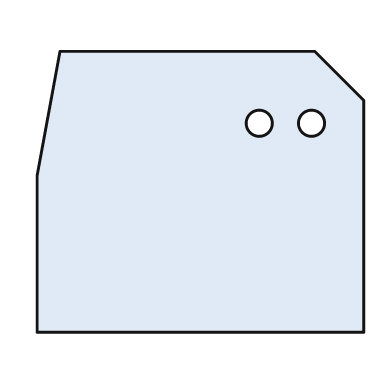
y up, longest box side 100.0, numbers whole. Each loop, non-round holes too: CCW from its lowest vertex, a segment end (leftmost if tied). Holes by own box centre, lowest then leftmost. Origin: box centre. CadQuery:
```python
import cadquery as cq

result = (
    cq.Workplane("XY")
    .moveTo(-50.0, -43.0)
    .lineTo(50.0, -43.0)
    .lineTo(50.0, 28.0)
    .lineTo(35.0, 43.0)
    .lineTo(-43.0, 43.0)
    .lineTo(-50.0, 5.0)
    .close()
    .moveTo(18.0, 21.0)
    .circle(4.0)
    .moveTo(34.0, 21.0)
    .circle(4.0)
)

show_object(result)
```